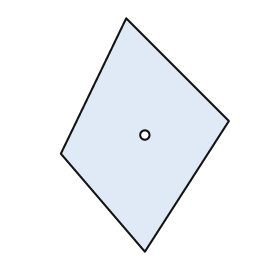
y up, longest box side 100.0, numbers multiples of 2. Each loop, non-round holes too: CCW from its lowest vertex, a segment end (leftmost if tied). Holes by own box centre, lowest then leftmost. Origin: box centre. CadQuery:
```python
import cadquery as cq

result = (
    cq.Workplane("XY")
    .moveTo(0.0, -50.0)
    .lineTo(36.0, 6.0)
    .lineTo(-8.0, 50.0)
    .lineTo(-36.0, -8.0)
    .close()
    .moveTo(0.0, 0.0)
    .circle(2.0)
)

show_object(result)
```